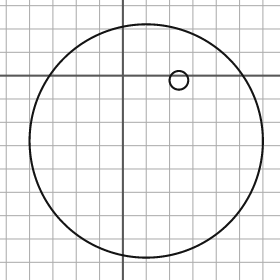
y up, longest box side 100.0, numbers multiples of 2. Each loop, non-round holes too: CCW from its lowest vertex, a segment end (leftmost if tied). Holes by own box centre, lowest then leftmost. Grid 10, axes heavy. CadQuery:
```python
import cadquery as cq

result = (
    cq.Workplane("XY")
    .moveTo(10.0, -28.0)
    .circle(50.0)
    .moveTo(24.0, -2.0)
    .circle(4.0)
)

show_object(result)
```